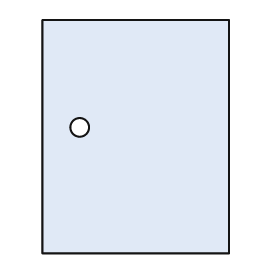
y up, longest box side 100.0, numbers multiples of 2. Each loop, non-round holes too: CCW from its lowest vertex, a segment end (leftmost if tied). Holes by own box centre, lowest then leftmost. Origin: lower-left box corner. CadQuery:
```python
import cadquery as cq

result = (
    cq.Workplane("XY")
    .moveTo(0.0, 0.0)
    .lineTo(80.0, 0.0)
    .lineTo(80.0, 100.0)
    .lineTo(0.0, 100.0)
    .close()
    .moveTo(16.0, 54.0)
    .circle(4.0)
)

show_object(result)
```